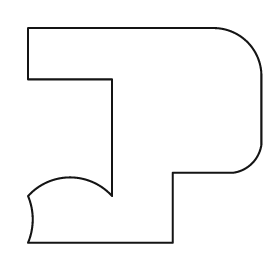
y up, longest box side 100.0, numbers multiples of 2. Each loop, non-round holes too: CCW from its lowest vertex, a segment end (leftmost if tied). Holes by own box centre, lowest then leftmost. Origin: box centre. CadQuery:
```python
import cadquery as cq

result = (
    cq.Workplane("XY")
    .moveTo(-50.0, -46.0)
    .lineTo(12.0, -46.0)
    .lineTo(12.0, -16.0)
    .lineTo(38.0, -16.0)
    .threePointArc((46.0, -12.0), (50.0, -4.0))
    .lineTo(50.0, 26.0)
    .threePointArc((44.0, 40.0), (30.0, 46.0))
    .lineTo(-50.0, 46.0)
    .lineTo(-50.0, 24.0)
    .lineTo(-14.0, 24.0)
    .lineTo(-14.0, -26.0)
    .threePointArc((-32.0, -18.0), (-50.0, -26.0))
    .threePointArc((-48.0, -36.0), (-50.0, -46.0))
    .close()
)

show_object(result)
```